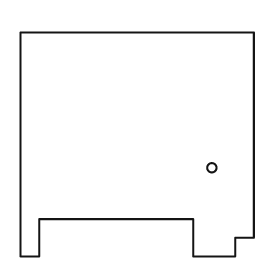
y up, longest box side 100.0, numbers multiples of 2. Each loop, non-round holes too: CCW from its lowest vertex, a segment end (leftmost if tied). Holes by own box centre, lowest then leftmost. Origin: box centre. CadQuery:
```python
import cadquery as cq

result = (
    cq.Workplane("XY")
    .moveTo(-50.0, -48.0)
    .lineTo(-42.0, -48.0)
    .lineTo(-42.0, -32.0)
    .lineTo(24.0, -32.0)
    .lineTo(24.0, -48.0)
    .lineTo(42.0, -48.0)
    .lineTo(42.0, -40.0)
    .lineTo(50.0, -40.0)
    .lineTo(50.0, 48.0)
    .lineTo(-50.0, 48.0)
    .close()
    .moveTo(32.0, -10.0)
    .circle(2.0)
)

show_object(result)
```